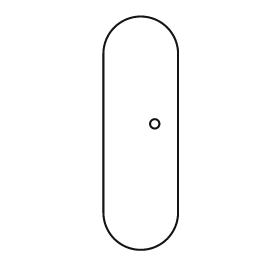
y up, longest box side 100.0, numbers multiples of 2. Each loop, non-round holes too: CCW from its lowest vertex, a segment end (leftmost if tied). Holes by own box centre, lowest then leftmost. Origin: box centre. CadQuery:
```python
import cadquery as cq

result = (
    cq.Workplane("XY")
    .moveTo(-16.0, -34.0)
    .threePointArc((0.0, -50.0), (16.0, -34.0))
    .lineTo(16.0, 34.0)
    .threePointArc((0.0, 50.0), (-16.0, 34.0))
    .close()
    .moveTo(6.0, 4.0)
    .circle(2.0)
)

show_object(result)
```